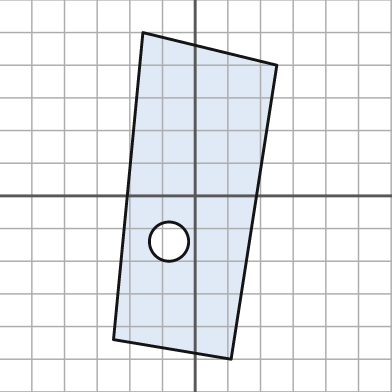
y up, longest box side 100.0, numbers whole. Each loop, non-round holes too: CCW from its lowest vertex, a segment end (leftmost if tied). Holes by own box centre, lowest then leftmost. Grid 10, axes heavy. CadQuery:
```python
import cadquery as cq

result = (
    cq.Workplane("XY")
    .moveTo(11.0, -50.0)
    .lineTo(25.0, 40.0)
    .lineTo(-16.0, 50.0)
    .lineTo(-25.0, -44.0)
    .close()
    .moveTo(-8.0, -14.0)
    .circle(6.0)
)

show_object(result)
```